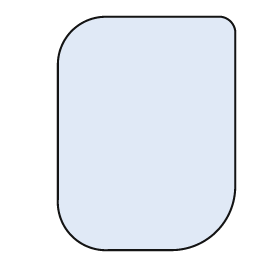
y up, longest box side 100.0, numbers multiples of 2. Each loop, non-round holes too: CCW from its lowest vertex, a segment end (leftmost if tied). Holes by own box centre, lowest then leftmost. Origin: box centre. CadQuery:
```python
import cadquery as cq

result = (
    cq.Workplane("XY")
    .moveTo(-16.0, -50.0)
    .lineTo(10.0, -50.0)
    .threePointArc((30.0, -42.0), (38.0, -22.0))
    .lineTo(38.0, 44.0)
    .threePointArc((36.0, 48.0), (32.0, 50.0))
    .lineTo(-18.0, 50.0)
    .threePointArc((-32.0, 44.0), (-38.0, 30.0))
    .lineTo(-38.0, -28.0)
    .threePointArc((-32.0, -44.0), (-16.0, -50.0))
    .close()
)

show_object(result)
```